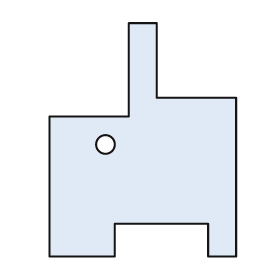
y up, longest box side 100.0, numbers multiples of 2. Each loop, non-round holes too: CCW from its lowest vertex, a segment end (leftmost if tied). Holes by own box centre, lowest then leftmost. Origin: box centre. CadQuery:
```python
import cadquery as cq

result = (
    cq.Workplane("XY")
    .moveTo(-40.0, -50.0)
    .lineTo(-12.0, -50.0)
    .lineTo(-12.0, -36.0)
    .lineTo(28.0, -36.0)
    .lineTo(28.0, -50.0)
    .lineTo(40.0, -50.0)
    .lineTo(40.0, 18.0)
    .lineTo(6.0, 18.0)
    .lineTo(6.0, 50.0)
    .lineTo(-6.0, 50.0)
    .lineTo(-6.0, 10.0)
    .lineTo(-40.0, 10.0)
    .close()
    .moveTo(-16.0, -2.0)
    .circle(4.0)
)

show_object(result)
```